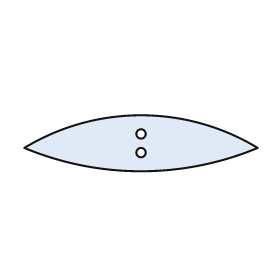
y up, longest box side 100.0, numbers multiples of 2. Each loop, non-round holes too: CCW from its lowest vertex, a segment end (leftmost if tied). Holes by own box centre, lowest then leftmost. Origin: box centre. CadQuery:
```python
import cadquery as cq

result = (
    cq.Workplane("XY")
    .moveTo(-50.0, -2.0)
    .threePointArc((0.0, -12.0), (50.0, -2.0))
    .threePointArc((0.0, 12.0), (-50.0, -2.0))
    .close()
    .moveTo(0.0, -4.0)
    .circle(2.0)
    .moveTo(0.0, 4.0)
    .circle(2.0)
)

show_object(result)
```